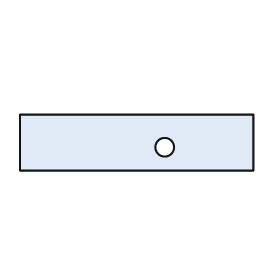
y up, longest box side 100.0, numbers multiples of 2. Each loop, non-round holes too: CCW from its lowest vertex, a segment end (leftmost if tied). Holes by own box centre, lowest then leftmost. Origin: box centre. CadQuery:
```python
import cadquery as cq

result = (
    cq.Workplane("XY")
    .moveTo(-50.0, -12.0)
    .lineTo(50.0, -12.0)
    .lineTo(50.0, 12.0)
    .lineTo(-50.0, 12.0)
    .close()
    .moveTo(12.0, -2.0)
    .circle(4.0)
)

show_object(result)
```